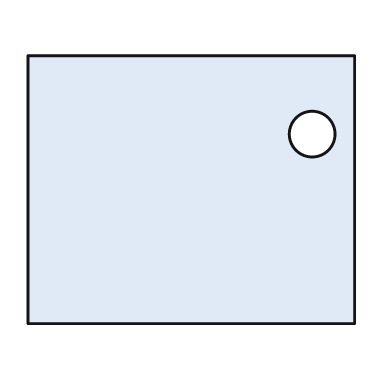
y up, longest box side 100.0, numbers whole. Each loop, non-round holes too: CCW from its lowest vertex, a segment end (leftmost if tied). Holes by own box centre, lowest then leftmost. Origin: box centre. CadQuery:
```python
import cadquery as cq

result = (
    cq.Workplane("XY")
    .moveTo(-50.0, -41.0)
    .lineTo(50.0, -41.0)
    .lineTo(50.0, 41.0)
    .lineTo(-50.0, 41.0)
    .close()
    .moveTo(37.0, 17.0)
    .circle(7.0)
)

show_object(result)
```